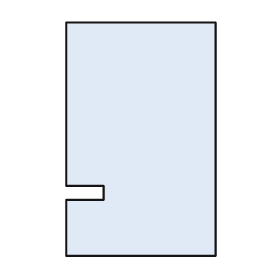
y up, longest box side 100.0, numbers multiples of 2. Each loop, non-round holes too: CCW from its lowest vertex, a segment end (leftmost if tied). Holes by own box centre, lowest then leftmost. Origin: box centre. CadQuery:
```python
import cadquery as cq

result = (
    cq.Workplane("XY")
    .moveTo(-32.0, -50.0)
    .lineTo(32.0, -50.0)
    .lineTo(32.0, 50.0)
    .lineTo(-32.0, 50.0)
    .lineTo(-32.0, -20.0)
    .lineTo(-16.0, -20.0)
    .lineTo(-16.0, -26.0)
    .lineTo(-32.0, -26.0)
    .close()
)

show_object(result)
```